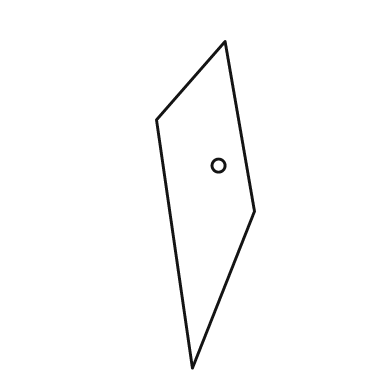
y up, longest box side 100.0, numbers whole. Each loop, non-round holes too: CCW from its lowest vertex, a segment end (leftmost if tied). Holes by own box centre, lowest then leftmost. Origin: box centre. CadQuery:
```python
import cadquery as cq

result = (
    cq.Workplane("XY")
    .moveTo(-4.0, -50.0)
    .lineTo(15.0, -2.0)
    .lineTo(6.0, 50.0)
    .lineTo(-15.0, 26.0)
    .close()
    .moveTo(4.0, 12.0)
    .circle(2.0)
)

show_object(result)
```